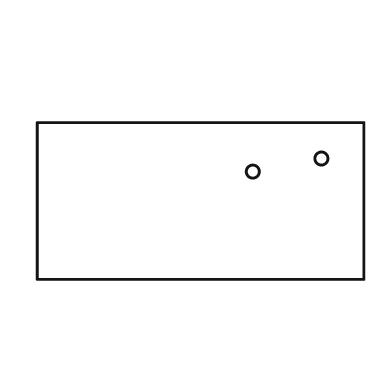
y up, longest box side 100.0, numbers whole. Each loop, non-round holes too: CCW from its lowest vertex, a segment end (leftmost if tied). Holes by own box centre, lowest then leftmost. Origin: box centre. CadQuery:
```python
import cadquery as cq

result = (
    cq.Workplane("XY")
    .moveTo(-50.0, -24.0)
    .lineTo(50.0, -24.0)
    .lineTo(50.0, 24.0)
    .lineTo(-50.0, 24.0)
    .close()
    .moveTo(16.0, 9.0)
    .circle(2.0)
    .moveTo(37.0, 13.0)
    .circle(2.0)
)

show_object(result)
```